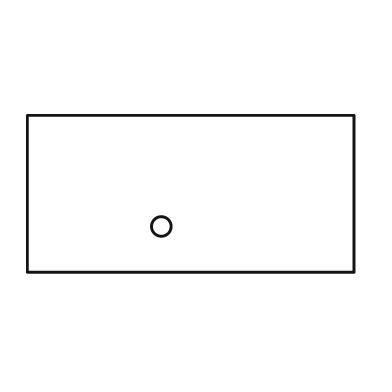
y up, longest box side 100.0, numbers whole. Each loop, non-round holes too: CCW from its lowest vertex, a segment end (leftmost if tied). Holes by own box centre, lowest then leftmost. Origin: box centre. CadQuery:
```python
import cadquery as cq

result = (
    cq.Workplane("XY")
    .moveTo(-50.0, -24.0)
    .lineTo(50.0, -24.0)
    .lineTo(50.0, 24.0)
    .lineTo(-50.0, 24.0)
    .close()
    .moveTo(-9.0, -10.0)
    .circle(3.0)
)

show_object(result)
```